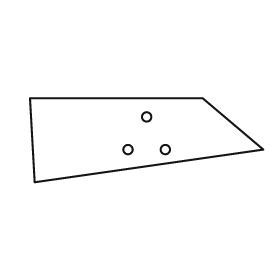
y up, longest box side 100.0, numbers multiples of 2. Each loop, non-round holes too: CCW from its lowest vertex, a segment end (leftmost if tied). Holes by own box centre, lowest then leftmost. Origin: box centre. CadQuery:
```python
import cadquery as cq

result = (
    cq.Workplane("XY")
    .moveTo(-48.0, -18.0)
    .lineTo(50.0, -4.0)
    .lineTo(24.0, 18.0)
    .lineTo(-50.0, 18.0)
    .close()
    .moveTo(-8.0, -4.0)
    .circle(2.0)
    .moveTo(8.0, -4.0)
    .circle(2.0)
    .moveTo(0.0, 10.0)
    .circle(2.0)
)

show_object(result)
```